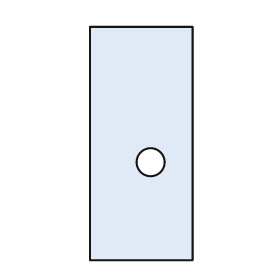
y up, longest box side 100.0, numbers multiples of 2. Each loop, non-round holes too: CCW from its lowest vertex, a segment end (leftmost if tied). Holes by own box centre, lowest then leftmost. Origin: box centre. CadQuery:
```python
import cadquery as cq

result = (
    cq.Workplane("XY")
    .moveTo(-22.0, -50.0)
    .lineTo(22.0, -50.0)
    .lineTo(22.0, 50.0)
    .lineTo(-22.0, 50.0)
    .close()
    .moveTo(4.0, -8.0)
    .circle(6.0)
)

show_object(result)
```